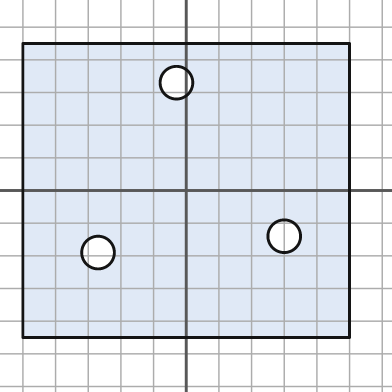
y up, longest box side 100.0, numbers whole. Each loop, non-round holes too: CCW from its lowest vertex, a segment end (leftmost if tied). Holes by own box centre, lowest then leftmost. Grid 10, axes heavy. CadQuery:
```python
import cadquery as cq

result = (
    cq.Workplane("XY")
    .moveTo(-50.0, -45.0)
    .lineTo(50.0, -45.0)
    .lineTo(50.0, 45.0)
    .lineTo(-50.0, 45.0)
    .close()
    .moveTo(-27.0, -19.0)
    .circle(5.0)
    .moveTo(30.0, -14.0)
    .circle(5.0)
    .moveTo(-3.0, 33.0)
    .circle(5.0)
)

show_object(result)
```